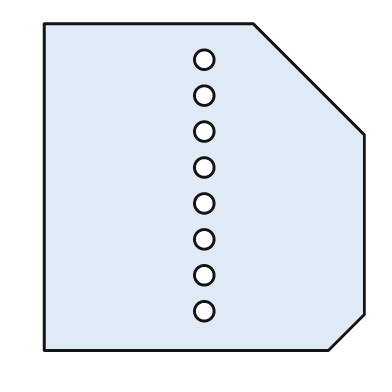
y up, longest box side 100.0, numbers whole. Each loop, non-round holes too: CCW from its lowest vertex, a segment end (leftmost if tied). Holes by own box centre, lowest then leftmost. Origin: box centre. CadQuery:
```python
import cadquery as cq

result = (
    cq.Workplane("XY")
    .moveTo(-49.0, -50.0)
    .lineTo(38.0, -50.0)
    .lineTo(49.0, -39.0)
    .lineTo(49.0, 16.0)
    .lineTo(15.0, 50.0)
    .lineTo(-49.0, 50.0)
    .close()
    .moveTo(0.0, -38.0)
    .circle(3.0)
    .moveTo(0.0, -27.0)
    .circle(3.0)
    .moveTo(0.0, -16.0)
    .circle(3.0)
    .moveTo(0.0, -5.0)
    .circle(3.0)
    .moveTo(0.0, 6.0)
    .circle(3.0)
    .moveTo(0.0, 17.0)
    .circle(3.0)
    .moveTo(0.0, 28.0)
    .circle(3.0)
    .moveTo(0.0, 39.0)
    .circle(3.0)
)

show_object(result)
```